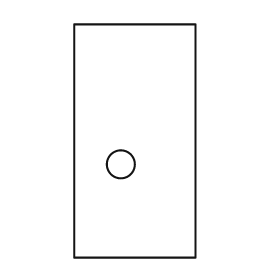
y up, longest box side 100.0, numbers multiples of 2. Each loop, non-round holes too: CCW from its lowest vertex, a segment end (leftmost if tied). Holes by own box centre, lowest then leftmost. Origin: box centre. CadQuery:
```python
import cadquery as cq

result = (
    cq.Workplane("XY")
    .moveTo(-26.0, -50.0)
    .lineTo(26.0, -50.0)
    .lineTo(26.0, 50.0)
    .lineTo(-26.0, 50.0)
    .close()
    .moveTo(-6.0, -10.0)
    .circle(6.0)
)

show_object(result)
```